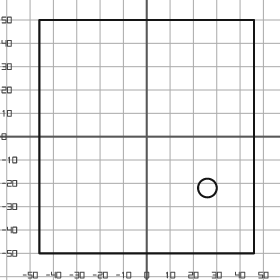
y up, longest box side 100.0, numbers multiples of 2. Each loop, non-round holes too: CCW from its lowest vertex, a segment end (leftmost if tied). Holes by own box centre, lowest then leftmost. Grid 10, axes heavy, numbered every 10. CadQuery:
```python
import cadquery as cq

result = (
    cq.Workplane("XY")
    .moveTo(-46.0, -50.0)
    .lineTo(46.0, -50.0)
    .lineTo(46.0, 50.0)
    .lineTo(-46.0, 50.0)
    .close()
    .moveTo(26.0, -22.0)
    .circle(4.0)
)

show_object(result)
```